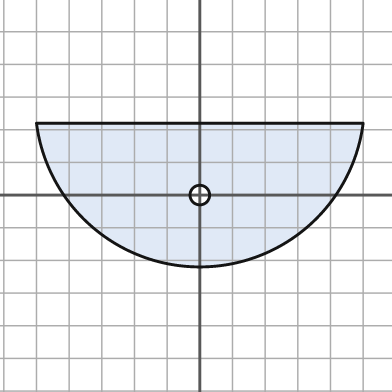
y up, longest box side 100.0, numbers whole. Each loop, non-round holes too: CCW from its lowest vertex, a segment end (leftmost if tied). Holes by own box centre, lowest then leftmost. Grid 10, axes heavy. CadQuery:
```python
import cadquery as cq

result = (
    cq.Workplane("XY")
    .moveTo(-50.0, 22.0)
    .threePointArc((0.0, -22.0), (50.0, 22.0))
    .close()
    .moveTo(0.0, 0.0)
    .circle(3.0)
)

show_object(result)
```